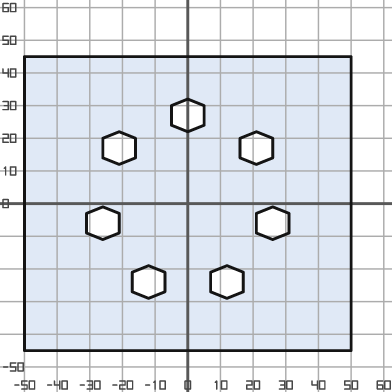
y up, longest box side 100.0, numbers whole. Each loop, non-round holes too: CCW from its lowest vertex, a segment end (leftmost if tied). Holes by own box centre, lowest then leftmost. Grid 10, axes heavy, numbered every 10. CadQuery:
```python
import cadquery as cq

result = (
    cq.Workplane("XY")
    .moveTo(-50.0, -45.0)
    .lineTo(50.0, -45.0)
    .lineTo(50.0, 45.0)
    .lineTo(-50.0, 45.0)
    .close()
    .moveTo(-12.0, -29.0)
    .lineTo(-7.0, -27.0)
    .lineTo(-7.0, -21.0)
    .lineTo(-12.0, -19.0)
    .lineTo(-17.0, -21.0)
    .lineTo(-17.0, -27.0)
    .close()
    .moveTo(12.0, -29.0)
    .lineTo(17.0, -27.0)
    .lineTo(17.0, -21.0)
    .lineTo(12.0, -19.0)
    .lineTo(7.0, -21.0)
    .lineTo(7.0, -27.0)
    .close()
    .moveTo(-26.0, -11.0)
    .lineTo(-21.0, -9.0)
    .lineTo(-21.0, -3.0)
    .lineTo(-26.0, -1.0)
    .lineTo(-31.0, -3.0)
    .lineTo(-31.0, -9.0)
    .close()
    .moveTo(26.0, -11.0)
    .lineTo(31.0, -9.0)
    .lineTo(31.0, -3.0)
    .lineTo(26.0, -1.0)
    .lineTo(21.0, -3.0)
    .lineTo(21.0, -9.0)
    .close()
    .moveTo(-21.0, 12.0)
    .lineTo(-16.0, 14.0)
    .lineTo(-16.0, 20.0)
    .lineTo(-21.0, 22.0)
    .lineTo(-26.0, 20.0)
    .lineTo(-26.0, 14.0)
    .close()
    .moveTo(21.0, 12.0)
    .lineTo(26.0, 14.0)
    .lineTo(26.0, 20.0)
    .lineTo(21.0, 22.0)
    .lineTo(16.0, 20.0)
    .lineTo(16.0, 14.0)
    .close()
    .moveTo(0.0, 22.0)
    .lineTo(5.0, 24.0)
    .lineTo(5.0, 30.0)
    .lineTo(0.0, 32.0)
    .lineTo(-5.0, 30.0)
    .lineTo(-5.0, 24.0)
    .close()
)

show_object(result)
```